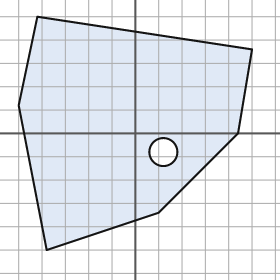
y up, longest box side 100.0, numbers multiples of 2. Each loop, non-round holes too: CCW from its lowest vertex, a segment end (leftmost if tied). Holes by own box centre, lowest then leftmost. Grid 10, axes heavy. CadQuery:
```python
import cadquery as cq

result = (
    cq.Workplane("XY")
    .moveTo(-38.0, -50.0)
    .lineTo(10.0, -34.0)
    .lineTo(44.0, 0.0)
    .lineTo(50.0, 36.0)
    .lineTo(-42.0, 50.0)
    .lineTo(-50.0, 12.0)
    .close()
    .moveTo(12.0, -8.0)
    .circle(6.0)
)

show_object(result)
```